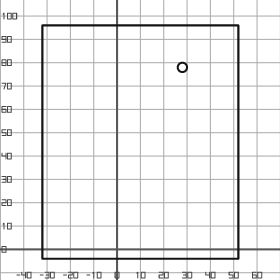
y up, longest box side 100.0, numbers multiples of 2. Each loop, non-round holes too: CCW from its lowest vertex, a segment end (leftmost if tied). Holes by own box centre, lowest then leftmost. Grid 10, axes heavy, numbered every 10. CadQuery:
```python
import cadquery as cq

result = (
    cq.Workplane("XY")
    .moveTo(-32.0, -4.0)
    .lineTo(52.0, -4.0)
    .lineTo(52.0, 96.0)
    .lineTo(-32.0, 96.0)
    .close()
    .moveTo(28.0, 78.0)
    .circle(2.0)
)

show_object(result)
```